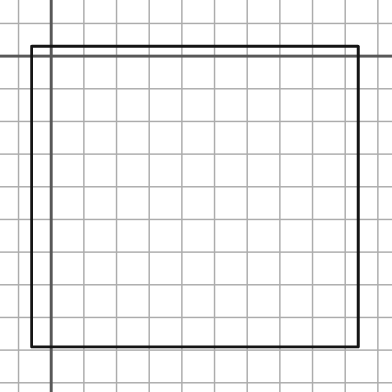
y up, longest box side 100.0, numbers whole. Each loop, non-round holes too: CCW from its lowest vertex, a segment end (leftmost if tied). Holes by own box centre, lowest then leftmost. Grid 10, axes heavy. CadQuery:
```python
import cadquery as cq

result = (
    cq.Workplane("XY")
    .moveTo(-6.0, -89.0)
    .lineTo(94.0, -89.0)
    .lineTo(94.0, 3.0)
    .lineTo(-6.0, 3.0)
    .close()
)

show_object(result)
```